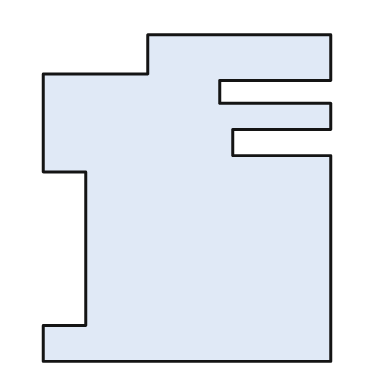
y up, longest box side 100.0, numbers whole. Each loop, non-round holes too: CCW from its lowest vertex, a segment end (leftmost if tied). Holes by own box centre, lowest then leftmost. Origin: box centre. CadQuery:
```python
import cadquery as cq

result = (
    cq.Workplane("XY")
    .moveTo(-44.0, -50.0)
    .lineTo(44.0, -50.0)
    .lineTo(44.0, 13.0)
    .lineTo(14.0, 13.0)
    .lineTo(14.0, 21.0)
    .lineTo(44.0, 21.0)
    .lineTo(44.0, 29.0)
    .lineTo(10.0, 29.0)
    .lineTo(10.0, 36.0)
    .lineTo(44.0, 36.0)
    .lineTo(44.0, 50.0)
    .lineTo(-12.0, 50.0)
    .lineTo(-12.0, 38.0)
    .lineTo(-44.0, 38.0)
    .lineTo(-44.0, 8.0)
    .lineTo(-31.0, 8.0)
    .lineTo(-31.0, -39.0)
    .lineTo(-44.0, -39.0)
    .close()
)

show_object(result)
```